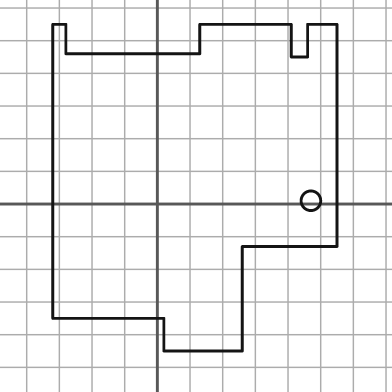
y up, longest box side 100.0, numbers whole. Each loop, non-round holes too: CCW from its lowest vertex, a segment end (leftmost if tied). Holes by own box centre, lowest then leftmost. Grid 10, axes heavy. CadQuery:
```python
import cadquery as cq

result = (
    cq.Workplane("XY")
    .moveTo(2.0, -45.0)
    .lineTo(26.0, -45.0)
    .lineTo(26.0, -13.0)
    .lineTo(55.0, -13.0)
    .lineTo(55.0, 55.0)
    .lineTo(46.0, 55.0)
    .lineTo(46.0, 45.0)
    .lineTo(41.0, 45.0)
    .lineTo(41.0, 55.0)
    .lineTo(13.0, 55.0)
    .lineTo(13.0, 46.0)
    .lineTo(-28.0, 46.0)
    .lineTo(-28.0, 55.0)
    .lineTo(-32.0, 55.0)
    .lineTo(-32.0, -35.0)
    .lineTo(2.0, -35.0)
    .close()
    .moveTo(47.0, 1.0)
    .circle(3.0)
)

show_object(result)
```